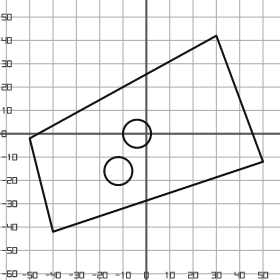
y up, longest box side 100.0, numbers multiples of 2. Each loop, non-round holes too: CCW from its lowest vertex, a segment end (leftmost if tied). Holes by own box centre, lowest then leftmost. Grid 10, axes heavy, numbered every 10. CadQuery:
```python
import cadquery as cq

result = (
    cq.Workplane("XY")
    .moveTo(-40.0, -42.0)
    .lineTo(50.0, -12.0)
    .lineTo(30.0, 42.0)
    .lineTo(-50.0, -2.0)
    .close()
    .moveTo(-12.0, -16.0)
    .circle(6.0)
    .moveTo(-4.0, 0.0)
    .circle(6.0)
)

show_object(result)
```